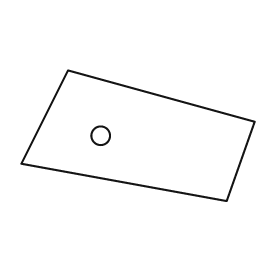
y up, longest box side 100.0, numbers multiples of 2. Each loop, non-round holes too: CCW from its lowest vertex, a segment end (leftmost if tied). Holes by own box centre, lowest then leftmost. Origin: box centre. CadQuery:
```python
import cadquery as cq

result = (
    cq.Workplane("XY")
    .moveTo(38.0, -28.0)
    .lineTo(50.0, 6.0)
    .lineTo(-30.0, 28.0)
    .lineTo(-50.0, -12.0)
    .close()
    .moveTo(-16.0, 0.0)
    .circle(4.0)
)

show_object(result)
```